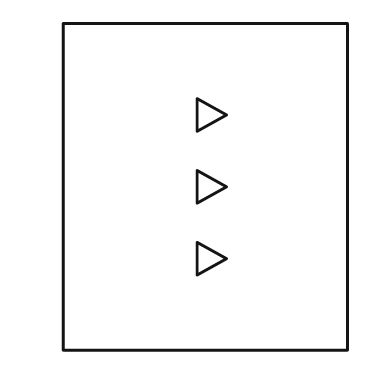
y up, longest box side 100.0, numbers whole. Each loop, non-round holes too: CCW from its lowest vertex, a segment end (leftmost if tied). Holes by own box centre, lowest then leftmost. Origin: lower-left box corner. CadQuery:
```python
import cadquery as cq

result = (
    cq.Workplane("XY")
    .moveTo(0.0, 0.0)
    .lineTo(87.0, 0.0)
    .lineTo(87.0, 100.0)
    .lineTo(0.0, 100.0)
    .close()
    .moveTo(41.0, 23.0)
    .lineTo(50.0, 28.0)
    .lineTo(41.0, 33.0)
    .close()
    .moveTo(41.0, 45.0)
    .lineTo(50.0, 50.0)
    .lineTo(41.0, 55.0)
    .close()
    .moveTo(41.0, 67.0)
    .lineTo(50.0, 72.0)
    .lineTo(41.0, 77.0)
    .close()
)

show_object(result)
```